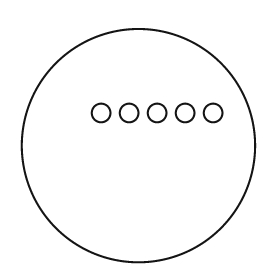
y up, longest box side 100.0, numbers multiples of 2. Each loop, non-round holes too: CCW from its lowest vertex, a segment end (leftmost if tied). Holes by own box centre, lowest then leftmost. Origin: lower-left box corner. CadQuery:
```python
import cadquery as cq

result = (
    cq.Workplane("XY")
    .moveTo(50.0, 50.0)
    .circle(50.0)
    .moveTo(34.0, 64.0)
    .circle(4.0)
    .moveTo(46.0, 64.0)
    .circle(4.0)
    .moveTo(58.0, 64.0)
    .circle(4.0)
    .moveTo(70.0, 64.0)
    .circle(4.0)
    .moveTo(82.0, 64.0)
    .circle(4.0)
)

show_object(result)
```